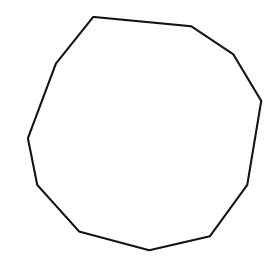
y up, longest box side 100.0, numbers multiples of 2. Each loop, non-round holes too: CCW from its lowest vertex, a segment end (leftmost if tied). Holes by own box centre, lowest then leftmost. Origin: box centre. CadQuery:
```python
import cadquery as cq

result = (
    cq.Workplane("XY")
    .moveTo(2.0, -50.0)
    .lineTo(28.0, -44.0)
    .lineTo(44.0, -22.0)
    .lineTo(50.0, 14.0)
    .lineTo(38.0, 34.0)
    .lineTo(20.0, 46.0)
    .lineTo(-22.0, 50.0)
    .lineTo(-38.0, 30.0)
    .lineTo(-50.0, -2.0)
    .lineTo(-46.0, -22.0)
    .lineTo(-28.0, -42.0)
    .close()
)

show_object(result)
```